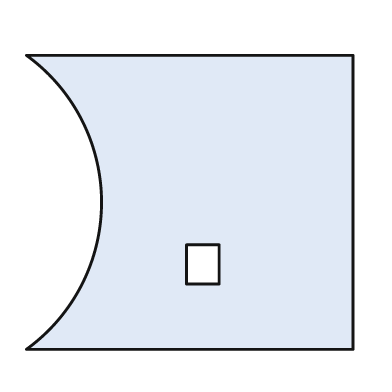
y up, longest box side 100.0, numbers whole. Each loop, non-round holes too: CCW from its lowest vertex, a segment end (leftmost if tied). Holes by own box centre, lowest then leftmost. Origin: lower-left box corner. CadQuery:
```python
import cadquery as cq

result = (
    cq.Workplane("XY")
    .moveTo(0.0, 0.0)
    .lineTo(100.0, 0.0)
    .lineTo(100.0, 90.0)
    .lineTo(0.0, 90.0)
    .threePointArc((23.0, 45.0), (0.0, 0.0))
    .close()
    .moveTo(49.0, 20.0)
    .lineTo(59.0, 20.0)
    .lineTo(59.0, 32.0)
    .lineTo(49.0, 32.0)
    .close()
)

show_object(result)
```